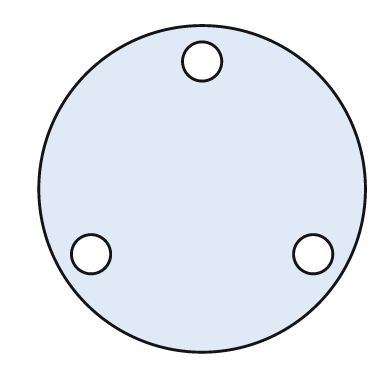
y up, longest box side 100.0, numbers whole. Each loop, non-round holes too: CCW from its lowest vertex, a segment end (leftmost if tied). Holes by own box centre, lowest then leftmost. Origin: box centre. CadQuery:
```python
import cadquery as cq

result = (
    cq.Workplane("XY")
    .moveTo(0.0, 0.0)
    .circle(50.0)
    .moveTo(-34.0, -20.0)
    .circle(6.0)
    .moveTo(34.0, -20.0)
    .circle(6.0)
    .moveTo(0.0, 39.0)
    .circle(6.0)
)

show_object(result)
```